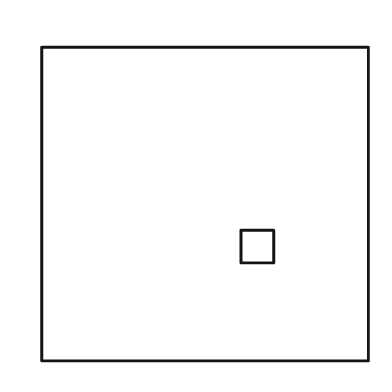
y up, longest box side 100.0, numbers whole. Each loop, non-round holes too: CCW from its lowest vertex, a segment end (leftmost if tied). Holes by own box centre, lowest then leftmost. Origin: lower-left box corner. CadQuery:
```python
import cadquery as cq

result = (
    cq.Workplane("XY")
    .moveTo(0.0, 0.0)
    .lineTo(100.0, 0.0)
    .lineTo(100.0, 96.0)
    .lineTo(0.0, 96.0)
    .close()
    .moveTo(61.0, 30.0)
    .lineTo(71.0, 30.0)
    .lineTo(71.0, 40.0)
    .lineTo(61.0, 40.0)
    .close()
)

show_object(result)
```